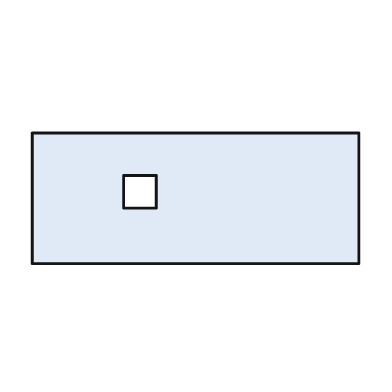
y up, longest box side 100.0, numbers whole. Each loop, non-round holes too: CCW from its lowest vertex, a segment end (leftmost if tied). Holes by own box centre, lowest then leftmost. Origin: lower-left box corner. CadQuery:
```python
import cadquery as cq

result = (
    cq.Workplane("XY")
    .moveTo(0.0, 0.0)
    .lineTo(100.0, 0.0)
    .lineTo(100.0, 40.0)
    .lineTo(0.0, 40.0)
    .close()
    .moveTo(28.0, 17.0)
    .lineTo(38.0, 17.0)
    .lineTo(38.0, 27.0)
    .lineTo(28.0, 27.0)
    .close()
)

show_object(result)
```